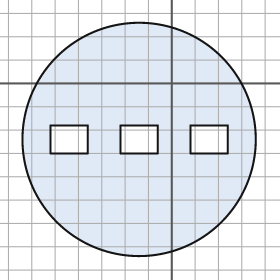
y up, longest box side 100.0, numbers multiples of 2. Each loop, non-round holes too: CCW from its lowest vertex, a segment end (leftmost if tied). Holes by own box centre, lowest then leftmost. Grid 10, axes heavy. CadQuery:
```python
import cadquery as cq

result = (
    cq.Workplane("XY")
    .moveTo(-14.0, -24.0)
    .circle(50.0)
    .moveTo(-52.0, -30.0)
    .lineTo(-36.0, -30.0)
    .lineTo(-36.0, -18.0)
    .lineTo(-52.0, -18.0)
    .close()
    .moveTo(-22.0, -30.0)
    .lineTo(-6.0, -30.0)
    .lineTo(-6.0, -18.0)
    .lineTo(-22.0, -18.0)
    .close()
    .moveTo(8.0, -30.0)
    .lineTo(24.0, -30.0)
    .lineTo(24.0, -18.0)
    .lineTo(8.0, -18.0)
    .close()
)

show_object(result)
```